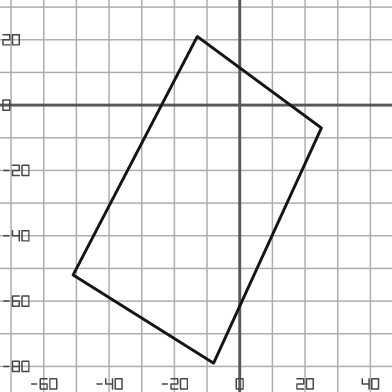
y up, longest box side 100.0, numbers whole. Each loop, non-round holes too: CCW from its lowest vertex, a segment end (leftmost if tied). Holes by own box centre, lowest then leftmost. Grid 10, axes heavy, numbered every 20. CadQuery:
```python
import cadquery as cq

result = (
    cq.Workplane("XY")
    .moveTo(-8.0, -79.0)
    .lineTo(25.0, -7.0)
    .lineTo(-13.0, 21.0)
    .lineTo(-51.0, -52.0)
    .close()
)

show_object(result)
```